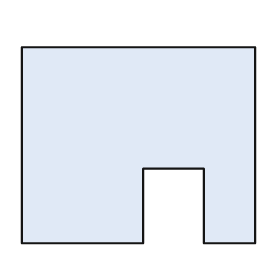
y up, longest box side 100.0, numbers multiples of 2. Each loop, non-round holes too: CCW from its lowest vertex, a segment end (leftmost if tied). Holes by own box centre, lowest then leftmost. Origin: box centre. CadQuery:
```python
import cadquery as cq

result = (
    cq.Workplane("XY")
    .moveTo(-50.0, -42.0)
    .lineTo(2.0, -42.0)
    .lineTo(2.0, -10.0)
    .lineTo(28.0, -10.0)
    .lineTo(28.0, -42.0)
    .lineTo(50.0, -42.0)
    .lineTo(50.0, 42.0)
    .lineTo(-50.0, 42.0)
    .close()
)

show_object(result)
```